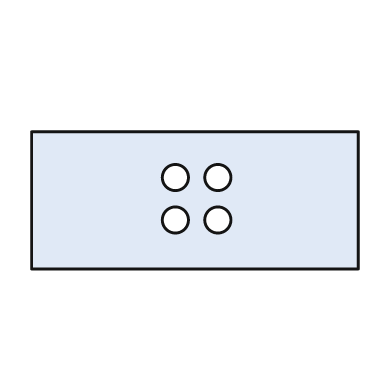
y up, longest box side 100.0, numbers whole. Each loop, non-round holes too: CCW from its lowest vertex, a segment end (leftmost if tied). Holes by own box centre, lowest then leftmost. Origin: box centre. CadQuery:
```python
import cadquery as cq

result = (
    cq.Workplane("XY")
    .moveTo(-50.0, -21.0)
    .lineTo(50.0, -21.0)
    .lineTo(50.0, 21.0)
    .lineTo(-50.0, 21.0)
    .close()
    .moveTo(-6.0, -6.0)
    .circle(4.0)
    .moveTo(7.0, -6.0)
    .circle(4.0)
    .moveTo(-6.0, 7.0)
    .circle(4.0)
    .moveTo(7.0, 7.0)
    .circle(4.0)
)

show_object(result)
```